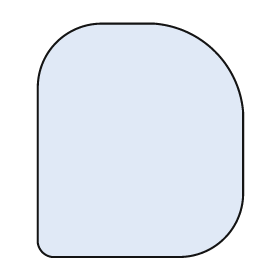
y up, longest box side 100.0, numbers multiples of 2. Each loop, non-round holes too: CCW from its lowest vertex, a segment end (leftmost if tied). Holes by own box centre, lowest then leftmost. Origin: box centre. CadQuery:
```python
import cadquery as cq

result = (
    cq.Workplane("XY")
    .moveTo(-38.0, -50.0)
    .lineTo(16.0, -50.0)
    .threePointArc((36.0, -42.0), (44.0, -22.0))
    .lineTo(44.0, 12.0)
    .threePointArc((32.0, 38.0), (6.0, 50.0))
    .lineTo(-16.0, 50.0)
    .threePointArc((-36.0, 42.0), (-44.0, 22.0))
    .lineTo(-44.0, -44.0)
    .threePointArc((-42.0, -48.0), (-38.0, -50.0))
    .close()
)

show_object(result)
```